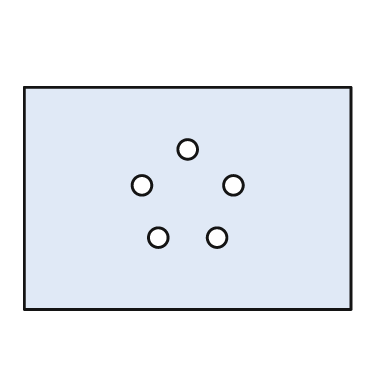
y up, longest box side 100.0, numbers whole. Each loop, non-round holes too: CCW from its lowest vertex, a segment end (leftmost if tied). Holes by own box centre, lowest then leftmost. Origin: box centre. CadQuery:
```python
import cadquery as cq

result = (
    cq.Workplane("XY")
    .moveTo(-50.0, -34.0)
    .lineTo(50.0, -34.0)
    .lineTo(50.0, 34.0)
    .lineTo(-50.0, 34.0)
    .close()
    .moveTo(-9.0, -12.0)
    .circle(3.0)
    .moveTo(9.0, -12.0)
    .circle(3.0)
    .moveTo(-14.0, 4.0)
    .circle(3.0)
    .moveTo(14.0, 4.0)
    .circle(3.0)
    .moveTo(0.0, 15.0)
    .circle(3.0)
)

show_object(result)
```